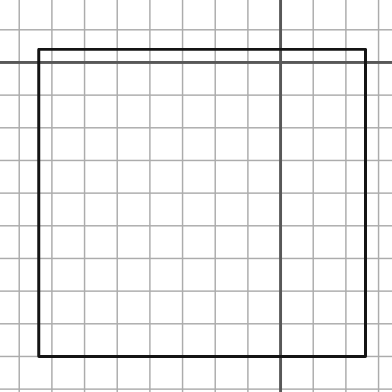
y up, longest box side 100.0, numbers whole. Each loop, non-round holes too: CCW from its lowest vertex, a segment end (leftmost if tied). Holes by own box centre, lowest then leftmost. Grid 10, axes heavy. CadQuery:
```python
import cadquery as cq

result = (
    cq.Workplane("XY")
    .moveTo(-74.0, -90.0)
    .lineTo(26.0, -90.0)
    .lineTo(26.0, 4.0)
    .lineTo(-74.0, 4.0)
    .close()
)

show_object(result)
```